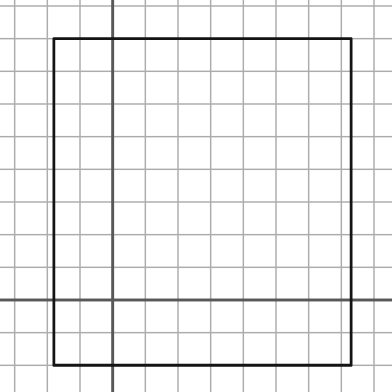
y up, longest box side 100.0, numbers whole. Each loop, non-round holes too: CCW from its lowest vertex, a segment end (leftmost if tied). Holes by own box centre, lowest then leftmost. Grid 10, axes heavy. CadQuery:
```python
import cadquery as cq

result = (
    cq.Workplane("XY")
    .moveTo(-18.0, -20.0)
    .lineTo(73.0, -20.0)
    .lineTo(73.0, 80.0)
    .lineTo(-18.0, 80.0)
    .close()
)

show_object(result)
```